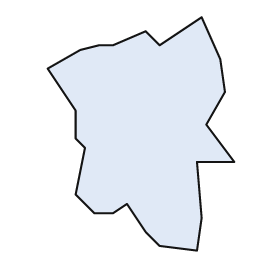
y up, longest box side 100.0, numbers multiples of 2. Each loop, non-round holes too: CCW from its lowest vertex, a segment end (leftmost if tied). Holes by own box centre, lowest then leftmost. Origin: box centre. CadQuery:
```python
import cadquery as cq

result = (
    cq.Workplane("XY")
    .moveTo(24.0, -50.0)
    .lineTo(26.0, -36.0)
    .lineTo(24.0, -12.0)
    .lineTo(40.0, -12.0)
    .lineTo(28.0, 4.0)
    .lineTo(36.0, 18.0)
    .lineTo(34.0, 32.0)
    .lineTo(26.0, 50.0)
    .lineTo(8.0, 38.0)
    .lineTo(2.0, 44.0)
    .lineTo(-12.0, 38.0)
    .lineTo(-18.0, 38.0)
    .lineTo(-26.0, 36.0)
    .lineTo(-40.0, 28.0)
    .lineTo(-28.0, 10.0)
    .lineTo(-28.0, -2.0)
    .lineTo(-24.0, -6.0)
    .lineTo(-28.0, -26.0)
    .lineTo(-20.0, -34.0)
    .lineTo(-12.0, -34.0)
    .lineTo(-6.0, -30.0)
    .lineTo(2.0, -42.0)
    .lineTo(8.0, -48.0)
    .close()
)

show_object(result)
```